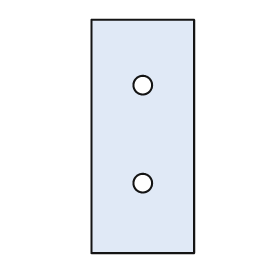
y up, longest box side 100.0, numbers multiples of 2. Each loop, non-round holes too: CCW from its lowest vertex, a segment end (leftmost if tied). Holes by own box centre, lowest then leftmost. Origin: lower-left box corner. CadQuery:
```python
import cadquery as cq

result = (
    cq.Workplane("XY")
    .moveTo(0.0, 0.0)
    .lineTo(44.0, 0.0)
    .lineTo(44.0, 100.0)
    .lineTo(0.0, 100.0)
    .close()
    .moveTo(22.0, 30.0)
    .circle(4.0)
    .moveTo(22.0, 72.0)
    .circle(4.0)
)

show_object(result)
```